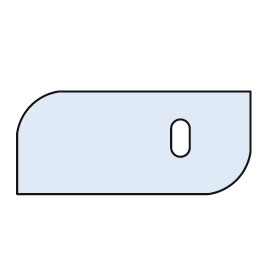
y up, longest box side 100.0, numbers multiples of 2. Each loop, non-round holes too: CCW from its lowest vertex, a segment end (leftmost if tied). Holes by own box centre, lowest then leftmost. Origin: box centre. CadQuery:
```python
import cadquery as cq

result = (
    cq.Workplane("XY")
    .moveTo(-50.0, -22.0)
    .lineTo(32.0, -22.0)
    .threePointArc((44.0, -16.0), (50.0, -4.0))
    .lineTo(50.0, 22.0)
    .lineTo(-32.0, 22.0)
    .threePointArc((-44.0, 16.0), (-50.0, 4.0))
    .close()
    .moveTo(16.0, -2.0)
    .threePointArc((20.0, -6.0), (24.0, -2.0))
    .lineTo(24.0, 6.0)
    .threePointArc((20.0, 10.0), (16.0, 6.0))
    .close()
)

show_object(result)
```